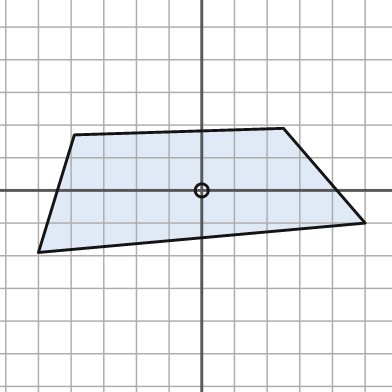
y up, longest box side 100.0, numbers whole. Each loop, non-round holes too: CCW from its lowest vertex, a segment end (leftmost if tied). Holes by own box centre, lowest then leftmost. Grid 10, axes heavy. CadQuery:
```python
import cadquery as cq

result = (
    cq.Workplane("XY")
    .moveTo(-50.0, -19.0)
    .lineTo(50.0, -10.0)
    .lineTo(25.0, 19.0)
    .lineTo(-39.0, 17.0)
    .close()
    .moveTo(0.0, 0.0)
    .circle(2.0)
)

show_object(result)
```